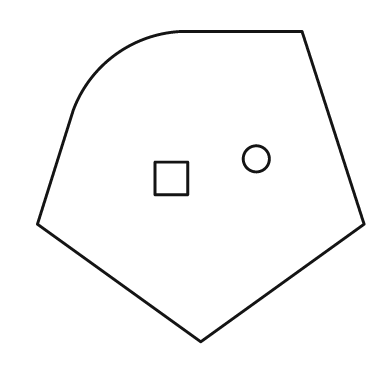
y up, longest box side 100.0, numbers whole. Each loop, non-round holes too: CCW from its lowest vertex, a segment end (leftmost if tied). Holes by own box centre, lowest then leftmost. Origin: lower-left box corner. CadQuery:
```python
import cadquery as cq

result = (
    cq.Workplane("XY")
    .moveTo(50.0, 0.0)
    .lineTo(100.0, 36.0)
    .lineTo(81.0, 95.0)
    .lineTo(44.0, 95.0)
    .threePointArc((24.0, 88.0), (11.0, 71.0))
    .lineTo(0.0, 36.0)
    .close()
    .moveTo(36.0, 45.0)
    .lineTo(46.0, 45.0)
    .lineTo(46.0, 55.0)
    .lineTo(36.0, 55.0)
    .close()
    .moveTo(67.0, 56.0)
    .circle(4.0)
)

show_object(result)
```